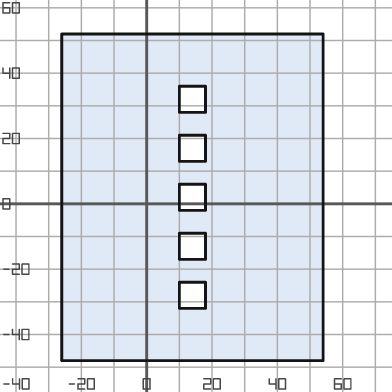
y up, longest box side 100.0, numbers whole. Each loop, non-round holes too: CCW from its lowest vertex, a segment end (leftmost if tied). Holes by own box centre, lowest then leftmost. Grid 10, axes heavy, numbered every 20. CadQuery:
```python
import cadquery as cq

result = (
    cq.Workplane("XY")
    .moveTo(-26.0, -48.0)
    .lineTo(54.0, -48.0)
    .lineTo(54.0, 52.0)
    .lineTo(-26.0, 52.0)
    .close()
    .moveTo(10.0, -32.0)
    .lineTo(18.0, -32.0)
    .lineTo(18.0, -24.0)
    .lineTo(10.0, -24.0)
    .close()
    .moveTo(10.0, -17.0)
    .lineTo(18.0, -17.0)
    .lineTo(18.0, -9.0)
    .lineTo(10.0, -9.0)
    .close()
    .moveTo(10.0, -2.0)
    .lineTo(18.0, -2.0)
    .lineTo(18.0, 6.0)
    .lineTo(10.0, 6.0)
    .close()
    .moveTo(10.0, 13.0)
    .lineTo(18.0, 13.0)
    .lineTo(18.0, 21.0)
    .lineTo(10.0, 21.0)
    .close()
    .moveTo(10.0, 28.0)
    .lineTo(18.0, 28.0)
    .lineTo(18.0, 36.0)
    .lineTo(10.0, 36.0)
    .close()
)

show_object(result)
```